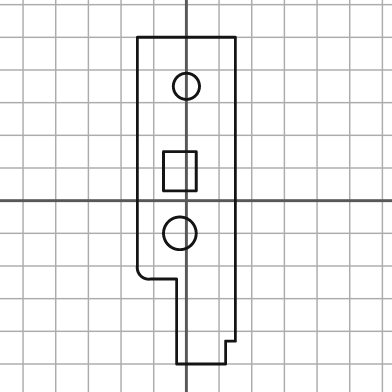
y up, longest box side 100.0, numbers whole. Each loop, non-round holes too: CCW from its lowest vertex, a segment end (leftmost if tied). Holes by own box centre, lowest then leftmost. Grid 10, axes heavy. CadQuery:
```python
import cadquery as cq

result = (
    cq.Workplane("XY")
    .moveTo(-3.0, -50.0)
    .lineTo(12.0, -50.0)
    .lineTo(12.0, -43.0)
    .lineTo(15.0, -43.0)
    .lineTo(15.0, 50.0)
    .lineTo(-15.0, 50.0)
    .lineTo(-15.0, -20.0)
    .threePointArc((-14.0, -23.0), (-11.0, -24.0))
    .lineTo(-3.0, -24.0)
    .close()
    .moveTo(-2.0, -10.0)
    .circle(5.0)
    .moveTo(-7.0, 3.0)
    .lineTo(3.0, 3.0)
    .lineTo(3.0, 15.0)
    .lineTo(-7.0, 15.0)
    .close()
    .moveTo(0.0, 35.0)
    .circle(4.0)
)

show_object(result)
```